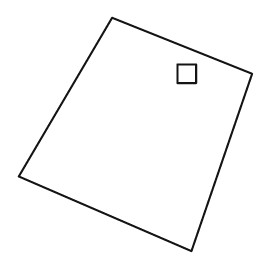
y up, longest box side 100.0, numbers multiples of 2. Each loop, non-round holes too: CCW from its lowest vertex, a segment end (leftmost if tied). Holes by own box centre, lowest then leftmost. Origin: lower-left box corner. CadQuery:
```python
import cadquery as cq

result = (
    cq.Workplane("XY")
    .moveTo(74.0, 0.0)
    .lineTo(100.0, 76.0)
    .lineTo(40.0, 100.0)
    .lineTo(0.0, 32.0)
    .close()
    .moveTo(68.0, 72.0)
    .lineTo(76.0, 72.0)
    .lineTo(76.0, 80.0)
    .lineTo(68.0, 80.0)
    .close()
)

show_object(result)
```